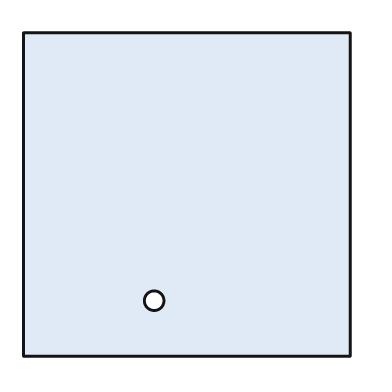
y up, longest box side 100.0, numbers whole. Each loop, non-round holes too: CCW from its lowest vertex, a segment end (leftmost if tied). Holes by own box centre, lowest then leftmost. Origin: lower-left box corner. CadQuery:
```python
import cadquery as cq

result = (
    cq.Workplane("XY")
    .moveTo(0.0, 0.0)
    .lineTo(100.0, 0.0)
    .lineTo(100.0, 99.0)
    .lineTo(0.0, 99.0)
    .close()
    .moveTo(40.0, 17.0)
    .circle(3.0)
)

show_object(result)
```